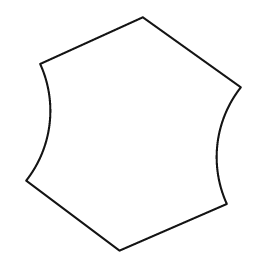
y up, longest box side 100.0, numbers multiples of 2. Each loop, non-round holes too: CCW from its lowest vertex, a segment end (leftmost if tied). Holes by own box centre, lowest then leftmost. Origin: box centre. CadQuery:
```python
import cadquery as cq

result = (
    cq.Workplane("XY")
    .moveTo(-6.0, -50.0)
    .lineTo(40.0, -30.0)
    .threePointArc((36.0, -4.0), (46.0, 20.0))
    .lineTo(4.0, 50.0)
    .lineTo(-40.0, 30.0)
    .threePointArc((-36.0, 4.0), (-46.0, -20.0))
    .close()
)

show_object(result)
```